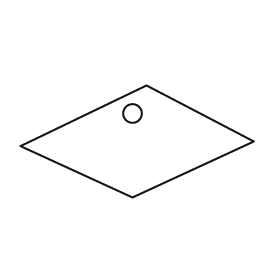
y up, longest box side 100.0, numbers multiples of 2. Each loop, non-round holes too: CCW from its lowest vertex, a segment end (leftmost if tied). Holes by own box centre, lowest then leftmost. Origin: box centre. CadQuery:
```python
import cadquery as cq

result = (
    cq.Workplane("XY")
    .moveTo(-2.0, -24.0)
    .lineTo(50.0, 0.0)
    .lineTo(4.0, 24.0)
    .lineTo(-50.0, -2.0)
    .close()
    .moveTo(-2.0, 12.0)
    .circle(4.0)
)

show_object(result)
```